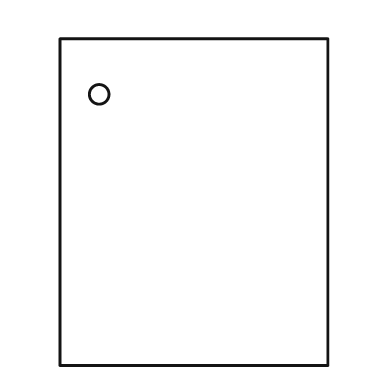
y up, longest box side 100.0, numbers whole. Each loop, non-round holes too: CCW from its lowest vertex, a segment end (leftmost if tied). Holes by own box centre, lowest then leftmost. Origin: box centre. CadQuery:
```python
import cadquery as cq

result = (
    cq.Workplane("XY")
    .moveTo(-41.0, -50.0)
    .lineTo(41.0, -50.0)
    .lineTo(41.0, 50.0)
    .lineTo(-41.0, 50.0)
    .close()
    .moveTo(-29.0, 33.0)
    .circle(3.0)
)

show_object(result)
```